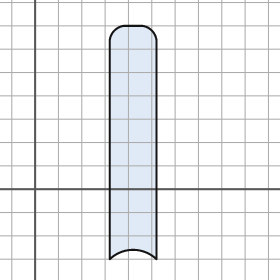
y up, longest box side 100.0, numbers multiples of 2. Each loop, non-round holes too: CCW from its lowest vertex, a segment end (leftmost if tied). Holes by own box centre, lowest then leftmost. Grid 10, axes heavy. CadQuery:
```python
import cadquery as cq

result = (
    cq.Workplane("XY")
    .moveTo(32.0, -30.0)
    .threePointArc((42.0, -26.0), (52.0, -30.0))
    .lineTo(52.0, 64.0)
    .threePointArc((50.0, 68.0), (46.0, 70.0))
    .lineTo(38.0, 70.0)
    .threePointArc((34.0, 68.0), (32.0, 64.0))
    .close()
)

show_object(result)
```